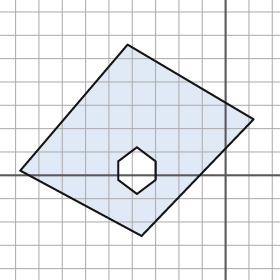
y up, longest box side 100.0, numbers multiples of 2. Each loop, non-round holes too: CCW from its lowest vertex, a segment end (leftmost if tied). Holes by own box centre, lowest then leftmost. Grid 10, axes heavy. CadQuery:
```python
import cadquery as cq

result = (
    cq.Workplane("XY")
    .moveTo(-36.0, -26.0)
    .lineTo(12.0, 24.0)
    .lineTo(-42.0, 56.0)
    .lineTo(-88.0, 2.0)
    .close()
    .moveTo(-38.0, -8.0)
    .lineTo(-30.0, -2.0)
    .lineTo(-30.0, 6.0)
    .lineTo(-38.0, 12.0)
    .lineTo(-46.0, 6.0)
    .lineTo(-46.0, -2.0)
    .close()
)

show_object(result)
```